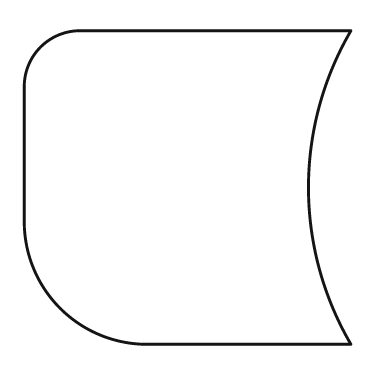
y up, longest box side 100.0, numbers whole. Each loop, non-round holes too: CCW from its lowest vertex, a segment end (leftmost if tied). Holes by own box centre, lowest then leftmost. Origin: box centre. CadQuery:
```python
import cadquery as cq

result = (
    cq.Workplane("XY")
    .moveTo(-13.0, -48.0)
    .lineTo(50.0, -48.0)
    .threePointArc((37.0, 0.0), (50.0, 48.0))
    .lineTo(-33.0, 48.0)
    .threePointArc((-45.0, 43.0), (-50.0, 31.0))
    .lineTo(-50.0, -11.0)
    .threePointArc((-39.0, -37.0), (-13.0, -48.0))
    .close()
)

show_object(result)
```